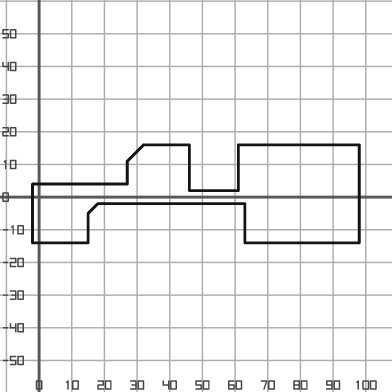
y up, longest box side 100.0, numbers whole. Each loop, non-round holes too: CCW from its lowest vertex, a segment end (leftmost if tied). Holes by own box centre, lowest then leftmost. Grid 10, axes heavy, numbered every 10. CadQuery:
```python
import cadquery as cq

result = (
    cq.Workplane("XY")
    .moveTo(-2.0, -14.0)
    .lineTo(15.0, -14.0)
    .lineTo(15.0, -5.0)
    .lineTo(18.0, -2.0)
    .lineTo(63.0, -2.0)
    .lineTo(63.0, -14.0)
    .lineTo(98.0, -14.0)
    .lineTo(98.0, 16.0)
    .lineTo(61.0, 16.0)
    .lineTo(61.0, 2.0)
    .lineTo(46.0, 2.0)
    .lineTo(46.0, 16.0)
    .lineTo(32.0, 16.0)
    .lineTo(27.0, 11.0)
    .lineTo(27.0, 4.0)
    .lineTo(-2.0, 4.0)
    .close()
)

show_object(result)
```